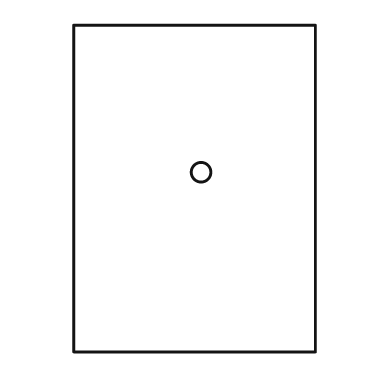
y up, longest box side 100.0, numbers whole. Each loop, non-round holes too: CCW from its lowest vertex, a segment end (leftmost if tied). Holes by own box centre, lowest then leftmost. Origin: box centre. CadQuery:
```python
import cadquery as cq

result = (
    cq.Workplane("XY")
    .moveTo(-37.0, -50.0)
    .lineTo(37.0, -50.0)
    .lineTo(37.0, 50.0)
    .lineTo(-37.0, 50.0)
    .close()
    .moveTo(2.0, 5.0)
    .circle(3.0)
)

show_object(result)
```